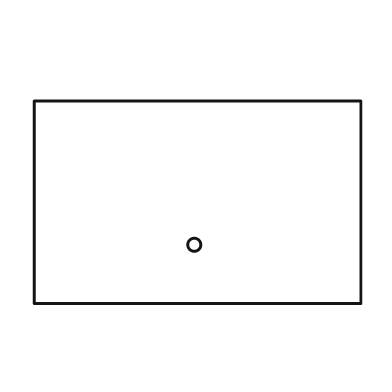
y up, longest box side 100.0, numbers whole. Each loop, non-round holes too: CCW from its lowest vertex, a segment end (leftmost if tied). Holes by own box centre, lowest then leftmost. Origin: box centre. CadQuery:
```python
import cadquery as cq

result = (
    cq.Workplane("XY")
    .moveTo(-50.0, -31.0)
    .lineTo(50.0, -31.0)
    .lineTo(50.0, 31.0)
    .lineTo(-50.0, 31.0)
    .close()
    .moveTo(-1.0, -13.0)
    .circle(2.0)
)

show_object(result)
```